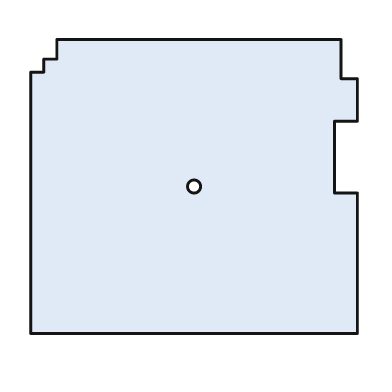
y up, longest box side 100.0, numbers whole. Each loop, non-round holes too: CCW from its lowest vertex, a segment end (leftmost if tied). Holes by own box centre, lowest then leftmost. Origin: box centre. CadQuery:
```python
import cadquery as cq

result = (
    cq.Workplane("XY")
    .moveTo(-50.0, -45.0)
    .lineTo(50.0, -45.0)
    .lineTo(50.0, -2.0)
    .lineTo(43.0, -2.0)
    .lineTo(43.0, 20.0)
    .lineTo(50.0, 20.0)
    .lineTo(50.0, 33.0)
    .lineTo(45.0, 33.0)
    .lineTo(45.0, 45.0)
    .lineTo(-42.0, 45.0)
    .lineTo(-42.0, 39.0)
    .lineTo(-46.0, 39.0)
    .lineTo(-46.0, 35.0)
    .lineTo(-50.0, 35.0)
    .close()
    .moveTo(0.0, 0.0)
    .circle(2.0)
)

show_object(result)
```